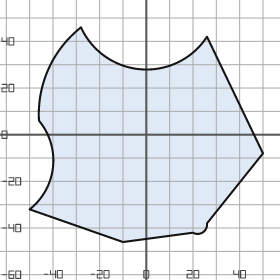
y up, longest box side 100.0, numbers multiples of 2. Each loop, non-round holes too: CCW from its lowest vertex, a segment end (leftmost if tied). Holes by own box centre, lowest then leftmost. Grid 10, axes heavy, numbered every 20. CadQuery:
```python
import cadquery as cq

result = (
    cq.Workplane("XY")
    .moveTo(-10.0, -46.0)
    .lineTo(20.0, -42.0)
    .threePointArc((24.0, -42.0), (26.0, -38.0))
    .lineTo(50.0, -8.0)
    .lineTo(26.0, 42.0)
    .threePointArc((-2.0, 28.0), (-28.0, 46.0))
    .threePointArc((-42.0, 28.0), (-46.0, 6.0))
    .threePointArc((-40.0, -14.0), (-50.0, -32.0))
    .close()
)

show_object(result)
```